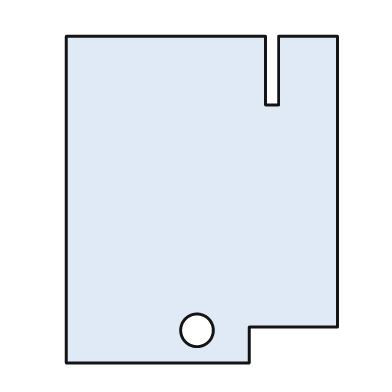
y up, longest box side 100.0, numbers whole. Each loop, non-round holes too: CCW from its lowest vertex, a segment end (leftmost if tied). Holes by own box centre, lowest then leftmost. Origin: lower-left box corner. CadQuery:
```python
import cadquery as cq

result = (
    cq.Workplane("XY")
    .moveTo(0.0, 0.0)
    .lineTo(56.0, 0.0)
    .lineTo(56.0, 11.0)
    .lineTo(83.0, 11.0)
    .lineTo(83.0, 100.0)
    .lineTo(65.0, 100.0)
    .lineTo(65.0, 79.0)
    .lineTo(61.0, 79.0)
    .lineTo(61.0, 100.0)
    .lineTo(0.0, 100.0)
    .close()
    .moveTo(40.0, 10.0)
    .circle(5.0)
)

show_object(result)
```